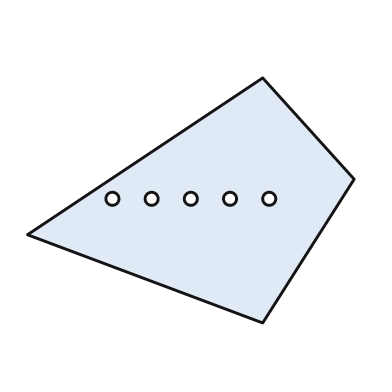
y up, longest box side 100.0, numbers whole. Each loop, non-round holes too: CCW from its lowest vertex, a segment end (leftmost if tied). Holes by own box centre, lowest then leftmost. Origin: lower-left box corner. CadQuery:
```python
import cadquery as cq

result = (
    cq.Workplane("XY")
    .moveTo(72.0, 0.0)
    .lineTo(100.0, 44.0)
    .lineTo(72.0, 75.0)
    .lineTo(0.0, 27.0)
    .close()
    .moveTo(26.0, 38.0)
    .circle(2.0)
    .moveTo(38.0, 38.0)
    .circle(2.0)
    .moveTo(50.0, 38.0)
    .circle(2.0)
    .moveTo(62.0, 38.0)
    .circle(2.0)
    .moveTo(74.0, 38.0)
    .circle(2.0)
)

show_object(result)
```